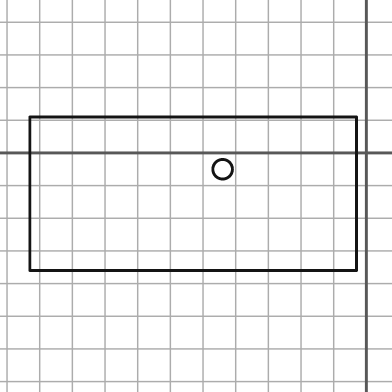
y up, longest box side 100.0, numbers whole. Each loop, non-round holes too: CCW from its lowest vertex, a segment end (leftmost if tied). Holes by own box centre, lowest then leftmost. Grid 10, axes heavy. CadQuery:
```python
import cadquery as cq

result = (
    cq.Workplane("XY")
    .moveTo(-103.0, -36.0)
    .lineTo(-3.0, -36.0)
    .lineTo(-3.0, 11.0)
    .lineTo(-103.0, 11.0)
    .close()
    .moveTo(-44.0, -5.0)
    .circle(3.0)
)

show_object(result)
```